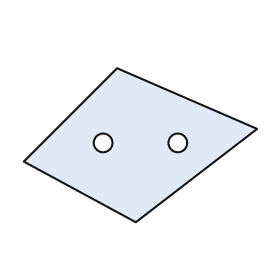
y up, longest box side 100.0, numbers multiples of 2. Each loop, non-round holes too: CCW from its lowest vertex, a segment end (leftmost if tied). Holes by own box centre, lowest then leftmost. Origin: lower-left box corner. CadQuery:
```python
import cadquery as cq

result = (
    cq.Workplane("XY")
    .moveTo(48.0, 0.0)
    .lineTo(100.0, 40.0)
    .lineTo(40.0, 66.0)
    .lineTo(0.0, 26.0)
    .close()
    .moveTo(34.0, 34.0)
    .circle(4.0)
    .moveTo(66.0, 34.0)
    .circle(4.0)
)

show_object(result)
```